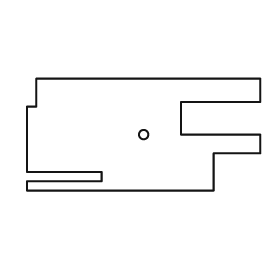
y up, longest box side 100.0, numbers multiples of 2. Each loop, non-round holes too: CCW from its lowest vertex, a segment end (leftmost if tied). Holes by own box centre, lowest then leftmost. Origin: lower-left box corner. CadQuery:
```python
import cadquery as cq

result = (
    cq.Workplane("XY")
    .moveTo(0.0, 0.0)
    .lineTo(80.0, 0.0)
    .lineTo(80.0, 16.0)
    .lineTo(100.0, 16.0)
    .lineTo(100.0, 24.0)
    .lineTo(66.0, 24.0)
    .lineTo(66.0, 38.0)
    .lineTo(100.0, 38.0)
    .lineTo(100.0, 48.0)
    .lineTo(4.0, 48.0)
    .lineTo(4.0, 36.0)
    .lineTo(0.0, 36.0)
    .lineTo(0.0, 8.0)
    .lineTo(32.0, 8.0)
    .lineTo(32.0, 4.0)
    .lineTo(0.0, 4.0)
    .close()
    .moveTo(50.0, 24.0)
    .circle(2.0)
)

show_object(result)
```